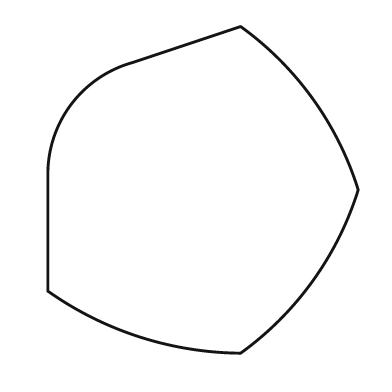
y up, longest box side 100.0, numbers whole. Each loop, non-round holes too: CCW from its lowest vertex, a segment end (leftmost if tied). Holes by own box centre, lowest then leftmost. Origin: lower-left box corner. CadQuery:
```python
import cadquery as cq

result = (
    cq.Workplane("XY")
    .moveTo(59.0, 0.0)
    .threePointArc((81.0, 22.0), (95.0, 50.0))
    .threePointArc((81.0, 78.0), (59.0, 100.0))
    .lineTo(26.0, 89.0)
    .threePointArc((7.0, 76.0), (0.0, 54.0))
    .lineTo(0.0, 19.0)
    .threePointArc((28.0, 5.0), (59.0, 0.0))
    .close()
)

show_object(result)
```